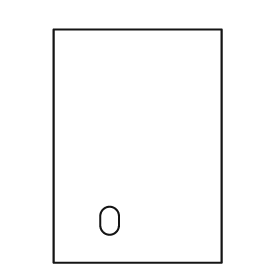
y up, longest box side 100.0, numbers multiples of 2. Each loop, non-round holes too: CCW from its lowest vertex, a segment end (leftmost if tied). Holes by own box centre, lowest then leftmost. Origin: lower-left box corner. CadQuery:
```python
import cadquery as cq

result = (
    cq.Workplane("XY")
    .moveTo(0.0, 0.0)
    .lineTo(72.0, 0.0)
    .lineTo(72.0, 100.0)
    .lineTo(0.0, 100.0)
    .close()
    .moveTo(20.0, 16.0)
    .threePointArc((24.0, 12.0), (28.0, 16.0))
    .lineTo(28.0, 20.0)
    .threePointArc((24.0, 24.0), (20.0, 20.0))
    .close()
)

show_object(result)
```